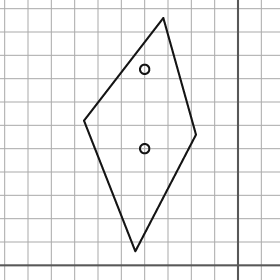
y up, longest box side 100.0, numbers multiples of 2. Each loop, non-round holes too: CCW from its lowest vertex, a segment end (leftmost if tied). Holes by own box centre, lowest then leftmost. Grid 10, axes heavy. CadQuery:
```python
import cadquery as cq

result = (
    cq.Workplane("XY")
    .moveTo(-44.0, 6.0)
    .lineTo(-18.0, 56.0)
    .lineTo(-32.0, 106.0)
    .lineTo(-66.0, 62.0)
    .close()
    .moveTo(-40.0, 50.0)
    .circle(2.0)
    .moveTo(-40.0, 84.0)
    .circle(2.0)
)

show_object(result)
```